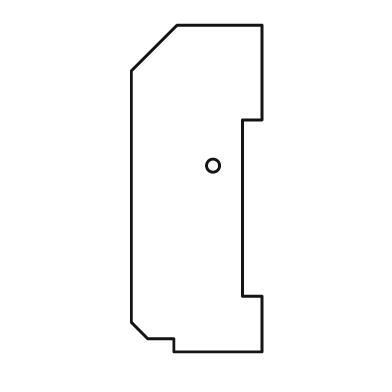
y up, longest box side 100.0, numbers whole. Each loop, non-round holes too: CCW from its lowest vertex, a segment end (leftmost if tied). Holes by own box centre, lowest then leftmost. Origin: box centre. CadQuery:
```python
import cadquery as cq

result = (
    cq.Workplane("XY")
    .moveTo(-7.0, -50.0)
    .lineTo(20.0, -50.0)
    .lineTo(20.0, -33.0)
    .lineTo(14.0, -33.0)
    .lineTo(14.0, 21.0)
    .lineTo(20.0, 21.0)
    .lineTo(20.0, 50.0)
    .lineTo(-6.0, 50.0)
    .lineTo(-20.0, 36.0)
    .lineTo(-20.0, -41.0)
    .lineTo(-15.0, -46.0)
    .lineTo(-7.0, -46.0)
    .close()
    .moveTo(5.0, 7.0)
    .circle(2.0)
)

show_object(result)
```